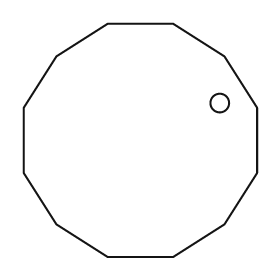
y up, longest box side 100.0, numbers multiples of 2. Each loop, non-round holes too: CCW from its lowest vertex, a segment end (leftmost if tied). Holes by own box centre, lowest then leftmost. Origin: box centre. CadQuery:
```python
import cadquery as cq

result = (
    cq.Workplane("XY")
    .moveTo(-14.0, -50.0)
    .lineTo(14.0, -50.0)
    .lineTo(36.0, -36.0)
    .lineTo(50.0, -14.0)
    .lineTo(50.0, 14.0)
    .lineTo(36.0, 36.0)
    .lineTo(14.0, 50.0)
    .lineTo(-14.0, 50.0)
    .lineTo(-36.0, 36.0)
    .lineTo(-50.0, 14.0)
    .lineTo(-50.0, -14.0)
    .lineTo(-36.0, -36.0)
    .close()
    .moveTo(34.0, 16.0)
    .circle(4.0)
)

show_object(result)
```